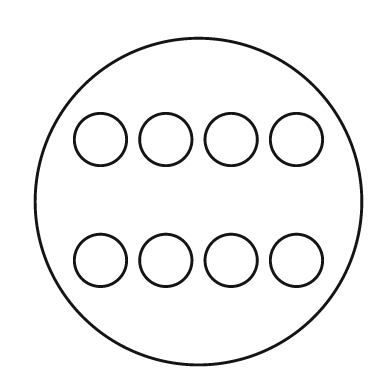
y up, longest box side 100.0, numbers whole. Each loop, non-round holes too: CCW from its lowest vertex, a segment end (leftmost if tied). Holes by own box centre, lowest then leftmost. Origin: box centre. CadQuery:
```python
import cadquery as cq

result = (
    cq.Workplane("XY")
    .moveTo(0.0, 0.0)
    .circle(50.0)
    .moveTo(-30.0, -18.0)
    .circle(8.0)
    .moveTo(-10.0, -18.0)
    .circle(8.0)
    .moveTo(10.0, -18.0)
    .circle(8.0)
    .moveTo(30.0, -18.0)
    .circle(8.0)
    .moveTo(-30.0, 19.0)
    .circle(8.0)
    .moveTo(-10.0, 19.0)
    .circle(8.0)
    .moveTo(10.0, 19.0)
    .circle(8.0)
    .moveTo(30.0, 19.0)
    .circle(8.0)
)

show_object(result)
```